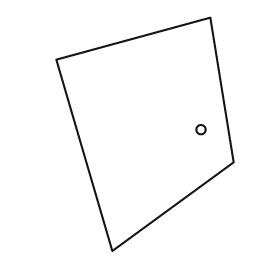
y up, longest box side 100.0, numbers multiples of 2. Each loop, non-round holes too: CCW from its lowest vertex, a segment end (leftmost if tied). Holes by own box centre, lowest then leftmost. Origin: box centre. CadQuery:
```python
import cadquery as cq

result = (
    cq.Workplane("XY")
    .moveTo(-14.0, -50.0)
    .lineTo(38.0, -12.0)
    .lineTo(28.0, 50.0)
    .lineTo(-38.0, 32.0)
    .close()
    .moveTo(24.0, 2.0)
    .circle(2.0)
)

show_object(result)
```